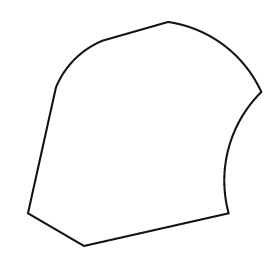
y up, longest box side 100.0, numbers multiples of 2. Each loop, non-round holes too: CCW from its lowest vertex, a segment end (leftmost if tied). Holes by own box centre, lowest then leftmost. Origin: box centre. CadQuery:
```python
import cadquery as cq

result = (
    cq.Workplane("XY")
    .moveTo(-26.0, -48.0)
    .lineTo(36.0, -34.0)
    .threePointArc((36.0, -6.0), (50.0, 18.0))
    .threePointArc((34.0, 38.0), (10.0, 48.0))
    .lineTo(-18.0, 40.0)
    .threePointArc((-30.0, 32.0), (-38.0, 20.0))
    .lineTo(-50.0, -34.0)
    .close()
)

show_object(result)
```